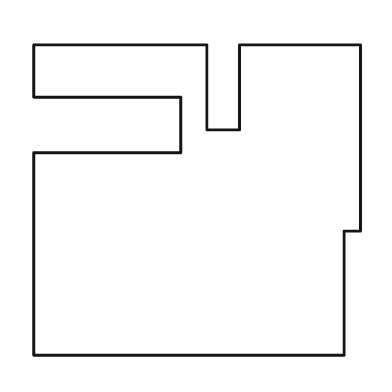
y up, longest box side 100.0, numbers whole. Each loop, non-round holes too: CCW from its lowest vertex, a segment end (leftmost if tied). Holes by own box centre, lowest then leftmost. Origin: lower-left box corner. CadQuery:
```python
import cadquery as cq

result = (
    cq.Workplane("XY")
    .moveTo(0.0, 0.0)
    .lineTo(95.0, 0.0)
    .lineTo(95.0, 38.0)
    .lineTo(100.0, 38.0)
    .lineTo(100.0, 95.0)
    .lineTo(63.0, 95.0)
    .lineTo(63.0, 69.0)
    .lineTo(53.0, 69.0)
    .lineTo(53.0, 95.0)
    .lineTo(0.0, 95.0)
    .lineTo(0.0, 79.0)
    .lineTo(45.0, 79.0)
    .lineTo(45.0, 62.0)
    .lineTo(0.0, 62.0)
    .close()
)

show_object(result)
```